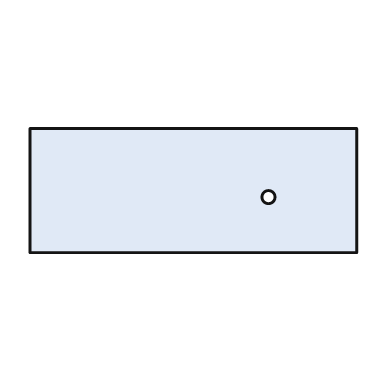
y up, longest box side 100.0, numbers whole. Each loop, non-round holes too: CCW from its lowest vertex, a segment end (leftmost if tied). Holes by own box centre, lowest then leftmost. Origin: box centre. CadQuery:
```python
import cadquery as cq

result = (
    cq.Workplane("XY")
    .moveTo(-50.0, -19.0)
    .lineTo(50.0, -19.0)
    .lineTo(50.0, 19.0)
    .lineTo(-50.0, 19.0)
    .close()
    .moveTo(23.0, -2.0)
    .circle(2.0)
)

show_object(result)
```